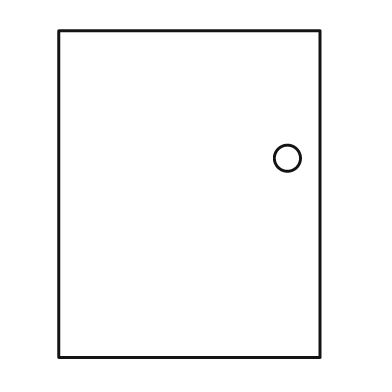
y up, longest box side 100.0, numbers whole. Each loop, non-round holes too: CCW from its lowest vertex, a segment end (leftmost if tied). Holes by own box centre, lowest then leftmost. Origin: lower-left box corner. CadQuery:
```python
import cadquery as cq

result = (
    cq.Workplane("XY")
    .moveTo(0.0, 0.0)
    .lineTo(80.0, 0.0)
    .lineTo(80.0, 100.0)
    .lineTo(0.0, 100.0)
    .close()
    .moveTo(70.0, 61.0)
    .circle(4.0)
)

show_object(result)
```